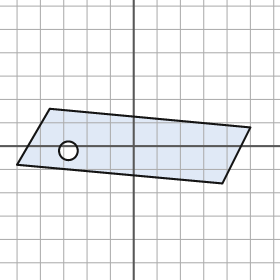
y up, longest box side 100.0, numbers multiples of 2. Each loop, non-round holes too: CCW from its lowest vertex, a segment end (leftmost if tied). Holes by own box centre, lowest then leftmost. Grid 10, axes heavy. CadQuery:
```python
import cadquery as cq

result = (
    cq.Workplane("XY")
    .moveTo(38.0, -16.0)
    .lineTo(50.0, 8.0)
    .lineTo(-36.0, 16.0)
    .lineTo(-50.0, -8.0)
    .close()
    .moveTo(-28.0, -2.0)
    .circle(4.0)
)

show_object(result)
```